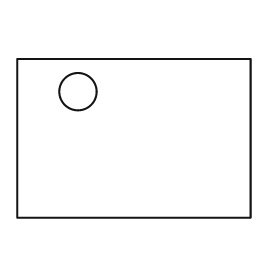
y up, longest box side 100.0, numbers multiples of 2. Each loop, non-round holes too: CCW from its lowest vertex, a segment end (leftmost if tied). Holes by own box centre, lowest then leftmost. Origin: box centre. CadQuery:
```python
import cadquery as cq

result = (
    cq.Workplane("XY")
    .moveTo(-50.0, -34.0)
    .lineTo(50.0, -34.0)
    .lineTo(50.0, 34.0)
    .lineTo(-50.0, 34.0)
    .close()
    .moveTo(-24.0, 20.0)
    .circle(8.0)
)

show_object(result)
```